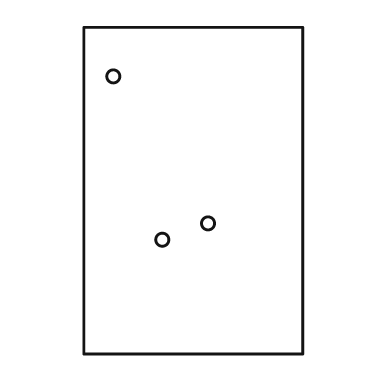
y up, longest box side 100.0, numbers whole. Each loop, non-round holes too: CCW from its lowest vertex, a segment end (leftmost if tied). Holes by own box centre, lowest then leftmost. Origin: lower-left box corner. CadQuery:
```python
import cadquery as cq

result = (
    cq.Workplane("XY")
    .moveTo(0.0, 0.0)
    .lineTo(67.0, 0.0)
    .lineTo(67.0, 100.0)
    .lineTo(0.0, 100.0)
    .close()
    .moveTo(24.0, 35.0)
    .circle(2.0)
    .moveTo(38.0, 40.0)
    .circle(2.0)
    .moveTo(9.0, 85.0)
    .circle(2.0)
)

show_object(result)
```